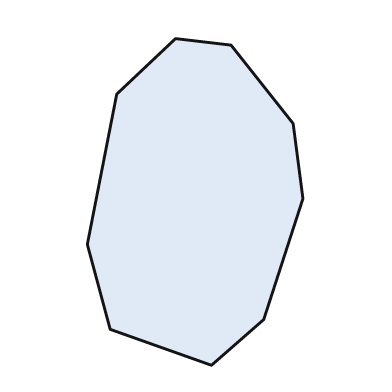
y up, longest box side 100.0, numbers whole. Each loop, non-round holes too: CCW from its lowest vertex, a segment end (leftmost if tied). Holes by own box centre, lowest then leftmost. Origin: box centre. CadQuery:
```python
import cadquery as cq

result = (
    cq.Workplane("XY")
    .moveTo(5.0, -50.0)
    .lineTo(21.0, -36.0)
    .lineTo(33.0, 1.0)
    .lineTo(30.0, 24.0)
    .lineTo(11.0, 48.0)
    .lineTo(-6.0, 50.0)
    .lineTo(-24.0, 33.0)
    .lineTo(-33.0, -13.0)
    .lineTo(-26.0, -39.0)
    .close()
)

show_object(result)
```